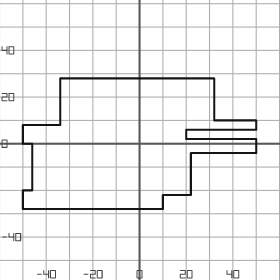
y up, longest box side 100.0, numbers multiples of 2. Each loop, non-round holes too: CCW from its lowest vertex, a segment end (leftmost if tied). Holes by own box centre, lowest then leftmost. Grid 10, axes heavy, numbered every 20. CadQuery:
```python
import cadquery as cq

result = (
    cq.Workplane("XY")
    .moveTo(-50.0, -28.0)
    .lineTo(10.0, -28.0)
    .lineTo(10.0, -22.0)
    .lineTo(22.0, -22.0)
    .lineTo(22.0, -4.0)
    .lineTo(50.0, -4.0)
    .lineTo(50.0, 2.0)
    .lineTo(20.0, 2.0)
    .lineTo(20.0, 6.0)
    .lineTo(50.0, 6.0)
    .lineTo(50.0, 10.0)
    .lineTo(32.0, 10.0)
    .lineTo(32.0, 28.0)
    .lineTo(-34.0, 28.0)
    .lineTo(-34.0, 8.0)
    .lineTo(-50.0, 8.0)
    .lineTo(-50.0, 0.0)
    .lineTo(-46.0, 0.0)
    .lineTo(-46.0, -20.0)
    .lineTo(-50.0, -20.0)
    .close()
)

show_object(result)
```